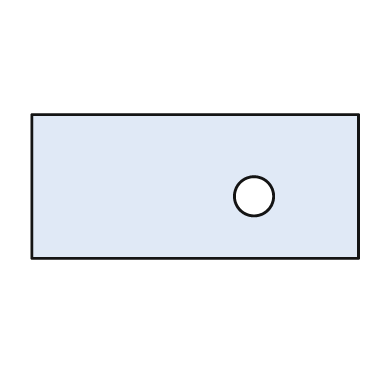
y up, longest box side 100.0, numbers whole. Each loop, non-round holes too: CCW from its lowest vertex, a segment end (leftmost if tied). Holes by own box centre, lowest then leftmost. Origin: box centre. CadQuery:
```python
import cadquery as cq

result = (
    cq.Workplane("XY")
    .moveTo(-50.0, -22.0)
    .lineTo(50.0, -22.0)
    .lineTo(50.0, 22.0)
    .lineTo(-50.0, 22.0)
    .close()
    .moveTo(18.0, -3.0)
    .circle(6.0)
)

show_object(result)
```